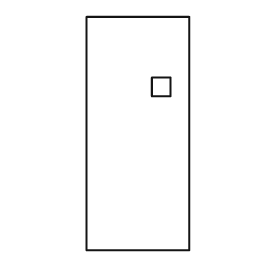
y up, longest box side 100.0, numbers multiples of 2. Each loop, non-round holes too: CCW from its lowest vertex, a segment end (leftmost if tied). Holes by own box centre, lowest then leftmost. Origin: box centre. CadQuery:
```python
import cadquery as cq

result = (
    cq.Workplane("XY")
    .moveTo(-22.0, -50.0)
    .lineTo(22.0, -50.0)
    .lineTo(22.0, 50.0)
    .lineTo(-22.0, 50.0)
    .close()
    .moveTo(6.0, 16.0)
    .lineTo(14.0, 16.0)
    .lineTo(14.0, 24.0)
    .lineTo(6.0, 24.0)
    .close()
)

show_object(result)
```